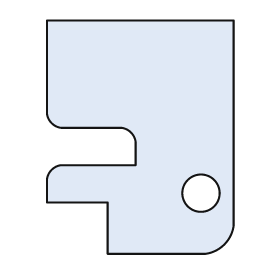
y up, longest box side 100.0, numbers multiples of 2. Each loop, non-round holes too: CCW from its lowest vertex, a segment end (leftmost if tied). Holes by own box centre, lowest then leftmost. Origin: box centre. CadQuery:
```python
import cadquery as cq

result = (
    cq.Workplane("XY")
    .moveTo(-14.0, -50.0)
    .lineTo(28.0, -50.0)
    .threePointArc((36.0, -46.0), (40.0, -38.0))
    .lineTo(40.0, 50.0)
    .lineTo(-40.0, 50.0)
    .lineTo(-40.0, 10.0)
    .threePointArc((-38.0, 6.0), (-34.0, 4.0))
    .lineTo(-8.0, 4.0)
    .threePointArc((-4.0, 2.0), (-2.0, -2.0))
    .lineTo(-2.0, -12.0)
    .lineTo(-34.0, -12.0)
    .threePointArc((-38.0, -14.0), (-40.0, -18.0))
    .lineTo(-40.0, -28.0)
    .lineTo(-14.0, -28.0)
    .close()
    .moveTo(26.0, -24.0)
    .circle(8.0)
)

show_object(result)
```